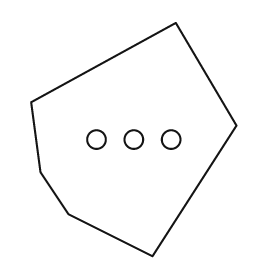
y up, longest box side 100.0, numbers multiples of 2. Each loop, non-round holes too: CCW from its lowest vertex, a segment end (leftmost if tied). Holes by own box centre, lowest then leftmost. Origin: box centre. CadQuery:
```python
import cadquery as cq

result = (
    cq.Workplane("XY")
    .moveTo(8.0, -50.0)
    .lineTo(44.0, 6.0)
    .lineTo(18.0, 50.0)
    .lineTo(-44.0, 16.0)
    .lineTo(-40.0, -14.0)
    .lineTo(-28.0, -32.0)
    .close()
    .moveTo(-16.0, 0.0)
    .circle(4.0)
    .moveTo(0.0, 0.0)
    .circle(4.0)
    .moveTo(16.0, 0.0)
    .circle(4.0)
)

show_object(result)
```